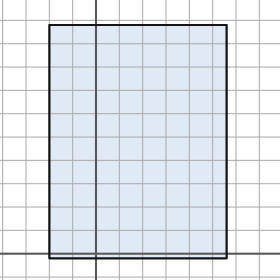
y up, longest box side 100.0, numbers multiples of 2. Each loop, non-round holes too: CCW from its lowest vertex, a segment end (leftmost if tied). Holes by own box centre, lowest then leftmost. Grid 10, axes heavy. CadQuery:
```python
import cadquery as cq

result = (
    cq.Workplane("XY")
    .moveTo(-20.0, -2.0)
    .lineTo(56.0, -2.0)
    .lineTo(56.0, 98.0)
    .lineTo(-20.0, 98.0)
    .close()
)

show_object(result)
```